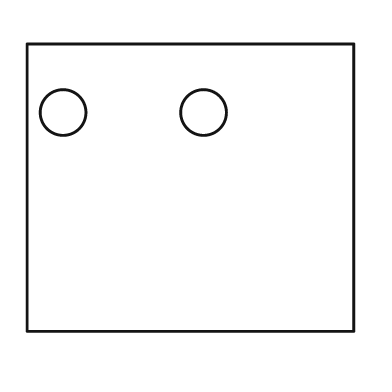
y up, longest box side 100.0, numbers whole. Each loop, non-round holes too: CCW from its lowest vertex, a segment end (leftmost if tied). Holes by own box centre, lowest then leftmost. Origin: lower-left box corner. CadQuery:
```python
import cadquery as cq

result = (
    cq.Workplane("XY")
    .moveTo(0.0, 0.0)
    .lineTo(100.0, 0.0)
    .lineTo(100.0, 88.0)
    .lineTo(0.0, 88.0)
    .close()
    .moveTo(11.0, 67.0)
    .circle(7.0)
    .moveTo(54.0, 67.0)
    .circle(7.0)
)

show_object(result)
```